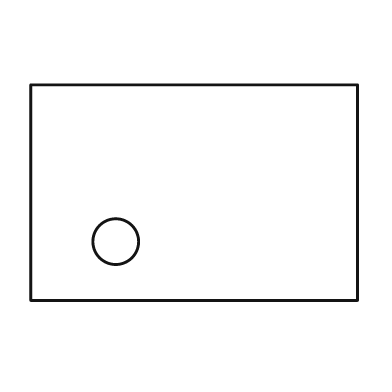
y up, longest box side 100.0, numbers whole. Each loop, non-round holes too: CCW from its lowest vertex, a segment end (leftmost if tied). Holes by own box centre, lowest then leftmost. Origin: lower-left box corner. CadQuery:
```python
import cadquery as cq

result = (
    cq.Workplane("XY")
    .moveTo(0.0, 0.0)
    .lineTo(100.0, 0.0)
    .lineTo(100.0, 66.0)
    .lineTo(0.0, 66.0)
    .close()
    .moveTo(26.0, 18.0)
    .circle(7.0)
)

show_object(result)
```